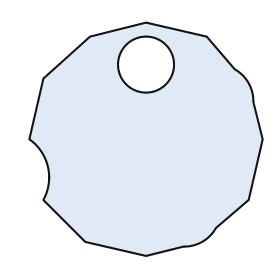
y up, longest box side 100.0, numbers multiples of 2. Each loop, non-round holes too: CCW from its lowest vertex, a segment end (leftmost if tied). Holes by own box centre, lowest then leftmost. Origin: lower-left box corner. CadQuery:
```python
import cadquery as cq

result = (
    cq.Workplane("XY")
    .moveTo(50.0, 0.0)
    .lineTo(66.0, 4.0)
    .threePointArc((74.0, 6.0), (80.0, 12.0))
    .lineTo(94.0, 24.0)
    .lineTo(100.0, 50.0)
    .lineTo(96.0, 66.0)
    .threePointArc((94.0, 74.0), (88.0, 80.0))
    .lineTo(76.0, 94.0)
    .lineTo(50.0, 100.0)
    .lineTo(26.0, 94.0)
    .lineTo(6.0, 76.0)
    .lineTo(0.0, 50.0)
    .threePointArc((8.0, 38.0), (6.0, 24.0))
    .lineTo(24.0, 6.0)
    .close()
    .moveTo(50.0, 82.0)
    .circle(12.0)
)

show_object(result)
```